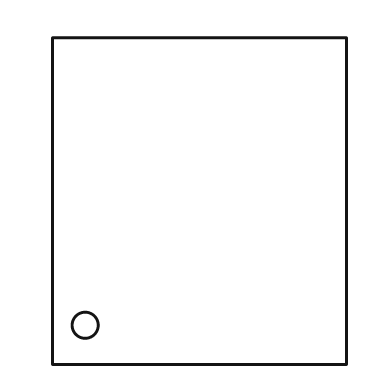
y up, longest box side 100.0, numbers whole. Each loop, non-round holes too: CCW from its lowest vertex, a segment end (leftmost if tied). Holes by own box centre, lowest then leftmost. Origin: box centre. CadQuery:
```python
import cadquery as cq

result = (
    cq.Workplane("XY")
    .moveTo(-45.0, -50.0)
    .lineTo(45.0, -50.0)
    .lineTo(45.0, 50.0)
    .lineTo(-45.0, 50.0)
    .close()
    .moveTo(-35.0, -38.0)
    .circle(4.0)
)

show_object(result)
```